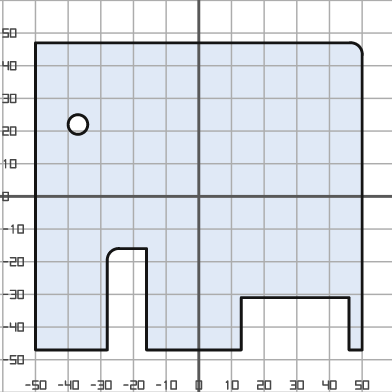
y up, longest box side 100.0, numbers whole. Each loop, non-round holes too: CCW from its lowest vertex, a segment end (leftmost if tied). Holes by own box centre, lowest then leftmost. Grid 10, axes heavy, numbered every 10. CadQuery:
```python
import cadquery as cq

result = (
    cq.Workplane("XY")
    .moveTo(-50.0, -47.0)
    .lineTo(-28.0, -47.0)
    .lineTo(-28.0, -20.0)
    .threePointArc((-27.0, -17.0), (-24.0, -16.0))
    .lineTo(-16.0, -16.0)
    .lineTo(-16.0, -47.0)
    .lineTo(13.0, -47.0)
    .lineTo(13.0, -31.0)
    .lineTo(46.0, -31.0)
    .lineTo(46.0, -47.0)
    .lineTo(50.0, -47.0)
    .lineTo(50.0, 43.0)
    .threePointArc((49.0, 46.0), (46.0, 47.0))
    .lineTo(-50.0, 47.0)
    .close()
    .moveTo(-37.0, 22.0)
    .circle(3.0)
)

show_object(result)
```